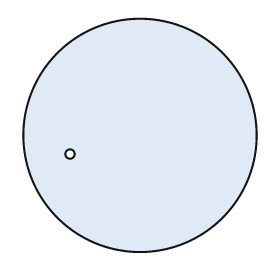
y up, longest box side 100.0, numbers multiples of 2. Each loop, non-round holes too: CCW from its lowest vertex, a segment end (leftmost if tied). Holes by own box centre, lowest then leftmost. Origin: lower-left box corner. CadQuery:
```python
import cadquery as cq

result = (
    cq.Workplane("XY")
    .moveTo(50.0, 50.0)
    .circle(50.0)
    .moveTo(20.0, 42.0)
    .circle(2.0)
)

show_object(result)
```